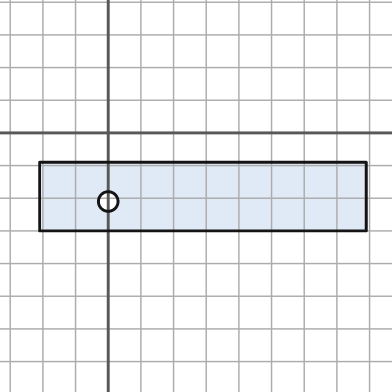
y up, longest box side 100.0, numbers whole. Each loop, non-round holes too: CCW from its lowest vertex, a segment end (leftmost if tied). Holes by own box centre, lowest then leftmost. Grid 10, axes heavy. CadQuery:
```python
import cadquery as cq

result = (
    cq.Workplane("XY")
    .moveTo(-21.0, -30.0)
    .lineTo(79.0, -30.0)
    .lineTo(79.0, -9.0)
    .lineTo(-21.0, -9.0)
    .close()
    .moveTo(0.0, -21.0)
    .circle(3.0)
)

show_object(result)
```